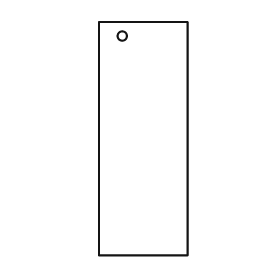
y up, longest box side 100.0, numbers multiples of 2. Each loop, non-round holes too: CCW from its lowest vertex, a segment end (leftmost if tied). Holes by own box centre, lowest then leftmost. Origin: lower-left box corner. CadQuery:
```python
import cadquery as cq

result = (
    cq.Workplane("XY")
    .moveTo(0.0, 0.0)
    .lineTo(38.0, 0.0)
    .lineTo(38.0, 100.0)
    .lineTo(0.0, 100.0)
    .close()
    .moveTo(10.0, 94.0)
    .circle(2.0)
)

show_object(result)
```